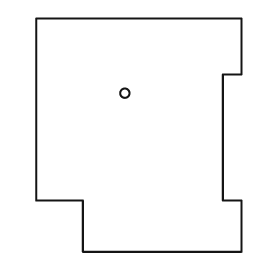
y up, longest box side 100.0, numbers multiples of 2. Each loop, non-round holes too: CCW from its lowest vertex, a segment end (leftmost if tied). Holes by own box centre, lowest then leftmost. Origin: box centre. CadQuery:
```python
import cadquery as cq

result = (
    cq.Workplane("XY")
    .moveTo(-24.0, -50.0)
    .lineTo(44.0, -50.0)
    .lineTo(44.0, -28.0)
    .lineTo(36.0, -28.0)
    .lineTo(36.0, 26.0)
    .lineTo(44.0, 26.0)
    .lineTo(44.0, 50.0)
    .lineTo(-44.0, 50.0)
    .lineTo(-44.0, -28.0)
    .lineTo(-24.0, -28.0)
    .close()
    .moveTo(-6.0, 18.0)
    .circle(2.0)
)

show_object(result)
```